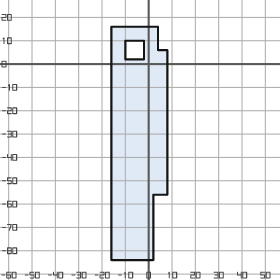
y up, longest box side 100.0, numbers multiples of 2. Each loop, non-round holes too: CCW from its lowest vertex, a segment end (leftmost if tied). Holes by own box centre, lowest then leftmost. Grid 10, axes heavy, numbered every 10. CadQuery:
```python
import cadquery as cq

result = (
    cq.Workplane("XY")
    .moveTo(-16.0, -84.0)
    .lineTo(2.0, -84.0)
    .lineTo(2.0, -56.0)
    .lineTo(8.0, -56.0)
    .lineTo(8.0, 6.0)
    .lineTo(4.0, 6.0)
    .lineTo(4.0, 16.0)
    .lineTo(-16.0, 16.0)
    .close()
    .moveTo(-10.0, 2.0)
    .lineTo(-2.0, 2.0)
    .lineTo(-2.0, 10.0)
    .lineTo(-10.0, 10.0)
    .close()
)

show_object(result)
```